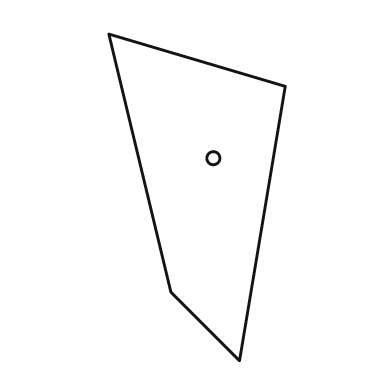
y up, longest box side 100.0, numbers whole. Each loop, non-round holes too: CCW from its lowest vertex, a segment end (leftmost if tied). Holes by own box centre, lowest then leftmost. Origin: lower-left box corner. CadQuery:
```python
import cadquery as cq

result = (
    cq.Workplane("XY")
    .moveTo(40.0, 0.0)
    .lineTo(54.0, 84.0)
    .lineTo(0.0, 100.0)
    .lineTo(19.0, 21.0)
    .close()
    .moveTo(32.0, 62.0)
    .circle(2.0)
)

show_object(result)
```